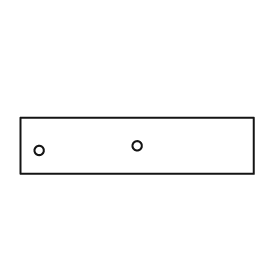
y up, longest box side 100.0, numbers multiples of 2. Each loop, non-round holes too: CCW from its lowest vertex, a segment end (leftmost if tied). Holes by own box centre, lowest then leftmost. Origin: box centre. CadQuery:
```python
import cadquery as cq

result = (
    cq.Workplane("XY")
    .moveTo(-50.0, -12.0)
    .lineTo(50.0, -12.0)
    .lineTo(50.0, 12.0)
    .lineTo(-50.0, 12.0)
    .close()
    .moveTo(-42.0, -2.0)
    .circle(2.0)
    .moveTo(0.0, 0.0)
    .circle(2.0)
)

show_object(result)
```